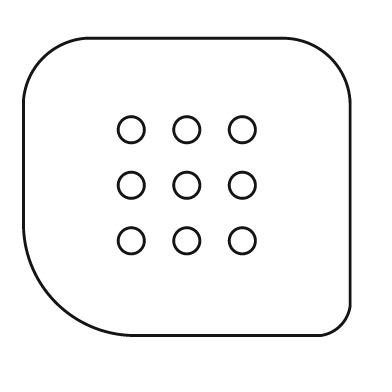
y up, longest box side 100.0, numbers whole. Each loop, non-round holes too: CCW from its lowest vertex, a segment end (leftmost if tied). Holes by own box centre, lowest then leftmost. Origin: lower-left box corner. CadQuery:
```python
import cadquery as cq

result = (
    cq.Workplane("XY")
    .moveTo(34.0, 0.0)
    .lineTo(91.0, 0.0)
    .threePointArc((97.0, 3.0), (100.0, 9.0))
    .lineTo(100.0, 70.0)
    .threePointArc((94.0, 85.0), (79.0, 91.0))
    .lineTo(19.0, 91.0)
    .threePointArc((6.0, 85.0), (0.0, 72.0))
    .lineTo(0.0, 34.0)
    .threePointArc((10.0, 10.0), (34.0, 0.0))
    .close()
    .moveTo(33.0, 29.0)
    .circle(4.0)
    .moveTo(50.0, 29.0)
    .circle(4.0)
    .moveTo(67.0, 29.0)
    .circle(4.0)
    .moveTo(33.0, 46.0)
    .circle(4.0)
    .moveTo(50.0, 46.0)
    .circle(4.0)
    .moveTo(67.0, 46.0)
    .circle(4.0)
    .moveTo(33.0, 63.0)
    .circle(4.0)
    .moveTo(50.0, 63.0)
    .circle(4.0)
    .moveTo(67.0, 63.0)
    .circle(4.0)
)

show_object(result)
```